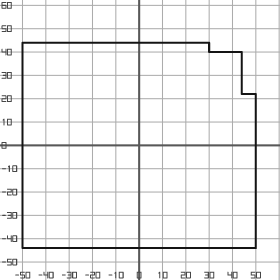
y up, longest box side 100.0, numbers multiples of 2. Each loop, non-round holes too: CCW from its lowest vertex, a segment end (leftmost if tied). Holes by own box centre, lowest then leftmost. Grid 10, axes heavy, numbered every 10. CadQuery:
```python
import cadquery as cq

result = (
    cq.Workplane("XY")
    .moveTo(-50.0, -44.0)
    .lineTo(50.0, -44.0)
    .lineTo(50.0, 22.0)
    .lineTo(44.0, 22.0)
    .lineTo(44.0, 40.0)
    .lineTo(30.0, 40.0)
    .lineTo(30.0, 44.0)
    .lineTo(-50.0, 44.0)
    .close()
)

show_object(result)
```